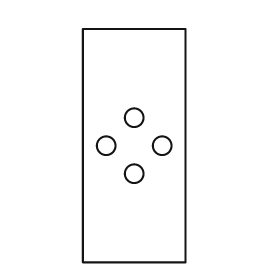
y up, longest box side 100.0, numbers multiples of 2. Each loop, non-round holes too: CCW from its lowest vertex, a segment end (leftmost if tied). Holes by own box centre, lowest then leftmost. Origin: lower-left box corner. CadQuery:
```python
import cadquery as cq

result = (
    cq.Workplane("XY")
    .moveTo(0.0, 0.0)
    .lineTo(44.0, 0.0)
    .lineTo(44.0, 100.0)
    .lineTo(0.0, 100.0)
    .close()
    .moveTo(22.0, 38.0)
    .circle(4.0)
    .moveTo(10.0, 50.0)
    .circle(4.0)
    .moveTo(34.0, 50.0)
    .circle(4.0)
    .moveTo(22.0, 62.0)
    .circle(4.0)
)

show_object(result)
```